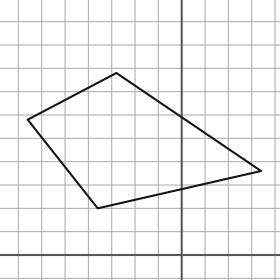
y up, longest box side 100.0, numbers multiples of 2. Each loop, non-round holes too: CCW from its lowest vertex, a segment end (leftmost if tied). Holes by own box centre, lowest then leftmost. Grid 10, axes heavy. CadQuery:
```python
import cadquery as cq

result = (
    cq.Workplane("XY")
    .moveTo(-36.0, 20.0)
    .lineTo(34.0, 36.0)
    .lineTo(-28.0, 78.0)
    .lineTo(-66.0, 58.0)
    .close()
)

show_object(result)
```